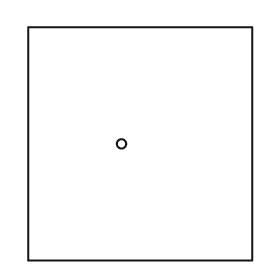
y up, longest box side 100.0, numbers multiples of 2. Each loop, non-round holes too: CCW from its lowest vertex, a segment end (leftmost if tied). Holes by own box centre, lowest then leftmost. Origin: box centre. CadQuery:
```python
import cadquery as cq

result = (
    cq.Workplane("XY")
    .moveTo(-48.0, -50.0)
    .lineTo(48.0, -50.0)
    .lineTo(48.0, 50.0)
    .lineTo(-48.0, 50.0)
    .close()
    .moveTo(-8.0, 0.0)
    .circle(2.0)
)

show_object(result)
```